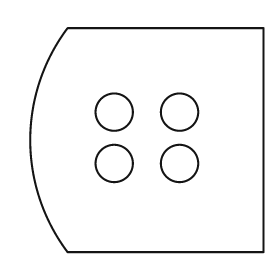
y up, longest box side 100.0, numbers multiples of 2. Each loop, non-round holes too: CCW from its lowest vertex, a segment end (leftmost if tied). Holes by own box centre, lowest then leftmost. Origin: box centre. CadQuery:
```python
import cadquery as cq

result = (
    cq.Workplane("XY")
    .moveTo(-34.0, -48.0)
    .lineTo(50.0, -48.0)
    .lineTo(50.0, 48.0)
    .lineTo(-34.0, 48.0)
    .threePointArc((-50.0, 0.0), (-34.0, -48.0))
    .close()
    .moveTo(-14.0, -10.0)
    .circle(8.0)
    .moveTo(14.0, -10.0)
    .circle(8.0)
    .moveTo(-14.0, 12.0)
    .circle(8.0)
    .moveTo(14.0, 12.0)
    .circle(8.0)
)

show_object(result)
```